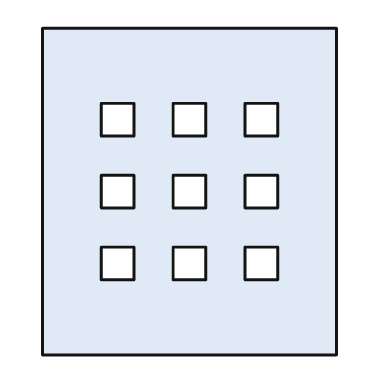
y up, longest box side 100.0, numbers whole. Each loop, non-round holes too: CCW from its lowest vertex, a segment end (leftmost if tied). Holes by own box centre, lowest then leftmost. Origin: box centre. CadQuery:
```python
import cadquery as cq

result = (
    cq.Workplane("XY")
    .moveTo(-45.0, -50.0)
    .lineTo(45.0, -50.0)
    .lineTo(45.0, 50.0)
    .lineTo(-45.0, 50.0)
    .close()
    .moveTo(-27.0, -27.0)
    .lineTo(-17.0, -27.0)
    .lineTo(-17.0, -17.0)
    .lineTo(-27.0, -17.0)
    .close()
    .moveTo(-5.0, -27.0)
    .lineTo(5.0, -27.0)
    .lineTo(5.0, -17.0)
    .lineTo(-5.0, -17.0)
    .close()
    .moveTo(17.0, -27.0)
    .lineTo(27.0, -27.0)
    .lineTo(27.0, -17.0)
    .lineTo(17.0, -17.0)
    .close()
    .moveTo(-27.0, -5.0)
    .lineTo(-17.0, -5.0)
    .lineTo(-17.0, 5.0)
    .lineTo(-27.0, 5.0)
    .close()
    .moveTo(-5.0, -5.0)
    .lineTo(5.0, -5.0)
    .lineTo(5.0, 5.0)
    .lineTo(-5.0, 5.0)
    .close()
    .moveTo(17.0, -5.0)
    .lineTo(27.0, -5.0)
    .lineTo(27.0, 5.0)
    .lineTo(17.0, 5.0)
    .close()
    .moveTo(-27.0, 17.0)
    .lineTo(-17.0, 17.0)
    .lineTo(-17.0, 27.0)
    .lineTo(-27.0, 27.0)
    .close()
    .moveTo(-5.0, 17.0)
    .lineTo(5.0, 17.0)
    .lineTo(5.0, 27.0)
    .lineTo(-5.0, 27.0)
    .close()
    .moveTo(17.0, 17.0)
    .lineTo(27.0, 17.0)
    .lineTo(27.0, 27.0)
    .lineTo(17.0, 27.0)
    .close()
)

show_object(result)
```